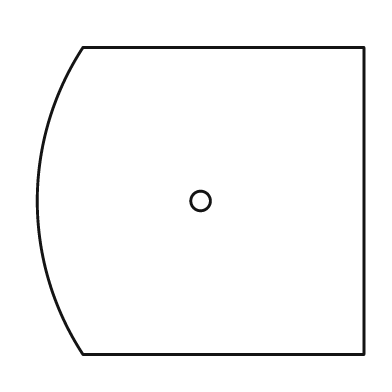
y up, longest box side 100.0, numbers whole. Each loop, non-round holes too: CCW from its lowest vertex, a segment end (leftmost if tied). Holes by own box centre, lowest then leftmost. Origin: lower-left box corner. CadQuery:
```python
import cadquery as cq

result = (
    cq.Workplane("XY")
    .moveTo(14.0, 0.0)
    .lineTo(100.0, 0.0)
    .lineTo(100.0, 94.0)
    .lineTo(14.0, 94.0)
    .threePointArc((0.0, 47.0), (14.0, 0.0))
    .close()
    .moveTo(50.0, 47.0)
    .circle(3.0)
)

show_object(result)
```